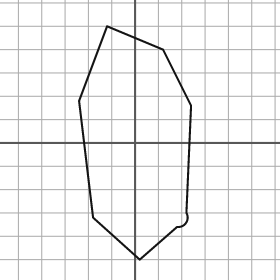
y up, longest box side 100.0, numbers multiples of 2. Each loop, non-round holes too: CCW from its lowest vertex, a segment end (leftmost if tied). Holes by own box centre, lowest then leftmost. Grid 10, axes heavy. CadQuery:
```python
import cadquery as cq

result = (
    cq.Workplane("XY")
    .moveTo(2.0, -50.0)
    .lineTo(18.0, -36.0)
    .threePointArc((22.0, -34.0), (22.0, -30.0))
    .lineTo(24.0, 16.0)
    .lineTo(12.0, 40.0)
    .lineTo(-12.0, 50.0)
    .lineTo(-24.0, 18.0)
    .lineTo(-18.0, -32.0)
    .close()
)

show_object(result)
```